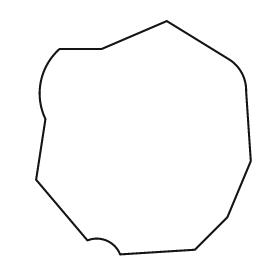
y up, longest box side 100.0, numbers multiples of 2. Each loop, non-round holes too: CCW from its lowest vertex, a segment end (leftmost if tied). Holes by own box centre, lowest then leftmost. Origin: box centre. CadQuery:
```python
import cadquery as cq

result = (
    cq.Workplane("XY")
    .moveTo(-10.0, -50.0)
    .lineTo(22.0, -48.0)
    .lineTo(36.0, -34.0)
    .lineTo(46.0, -10.0)
    .lineTo(44.0, 20.0)
    .threePointArc((42.0, 28.0), (36.0, 34.0))
    .lineTo(10.0, 50.0)
    .lineTo(-18.0, 38.0)
    .lineTo(-36.0, 38.0)
    .threePointArc((-44.0, 24.0), (-42.0, 8.0))
    .lineTo(-46.0, -18.0)
    .lineTo(-24.0, -44.0)
    .threePointArc((-16.0, -44.0), (-10.0, -50.0))
    .close()
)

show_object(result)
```